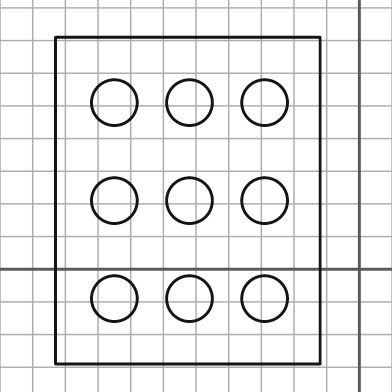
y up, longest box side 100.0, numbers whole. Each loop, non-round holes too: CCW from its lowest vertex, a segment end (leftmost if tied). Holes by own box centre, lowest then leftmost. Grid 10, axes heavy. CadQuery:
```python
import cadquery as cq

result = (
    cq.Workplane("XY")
    .moveTo(-93.0, -29.0)
    .lineTo(-12.0, -29.0)
    .lineTo(-12.0, 71.0)
    .lineTo(-93.0, 71.0)
    .close()
    .moveTo(-75.0, -9.0)
    .circle(7.0)
    .moveTo(-52.0, -9.0)
    .circle(7.0)
    .moveTo(-29.0, -9.0)
    .circle(7.0)
    .moveTo(-75.0, 21.0)
    .circle(7.0)
    .moveTo(-52.0, 21.0)
    .circle(7.0)
    .moveTo(-29.0, 21.0)
    .circle(7.0)
    .moveTo(-75.0, 51.0)
    .circle(7.0)
    .moveTo(-52.0, 51.0)
    .circle(7.0)
    .moveTo(-29.0, 51.0)
    .circle(7.0)
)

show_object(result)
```